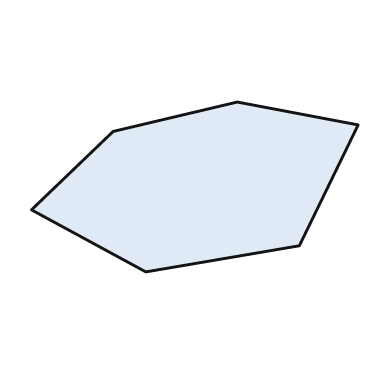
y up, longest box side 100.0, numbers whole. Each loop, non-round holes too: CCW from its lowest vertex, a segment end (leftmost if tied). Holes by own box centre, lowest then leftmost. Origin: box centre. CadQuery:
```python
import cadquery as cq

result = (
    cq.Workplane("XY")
    .moveTo(-15.0, -26.0)
    .lineTo(32.0, -18.0)
    .lineTo(50.0, 19.0)
    .lineTo(13.0, 26.0)
    .lineTo(-25.0, 17.0)
    .lineTo(-50.0, -7.0)
    .close()
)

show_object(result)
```